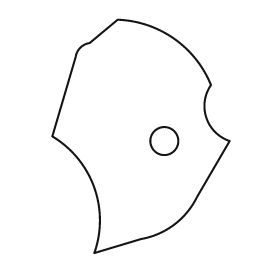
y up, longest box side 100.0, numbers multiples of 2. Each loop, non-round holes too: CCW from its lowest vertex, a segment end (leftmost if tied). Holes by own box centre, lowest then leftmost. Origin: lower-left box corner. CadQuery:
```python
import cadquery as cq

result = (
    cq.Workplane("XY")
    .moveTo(18.0, 0.0)
    .lineTo(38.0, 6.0)
    .threePointArc((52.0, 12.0), (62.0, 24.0))
    .lineTo(76.0, 48.0)
    .threePointArc((66.0, 58.0), (68.0, 72.0))
    .threePointArc((52.0, 92.0), (28.0, 100.0))
    .lineTo(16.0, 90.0)
    .threePointArc((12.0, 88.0), (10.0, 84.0))
    .lineTo(0.0, 50.0)
    .threePointArc((18.0, 28.0), (18.0, 0.0))
    .close()
    .moveTo(48.0, 48.0)
    .circle(6.0)
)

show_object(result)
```